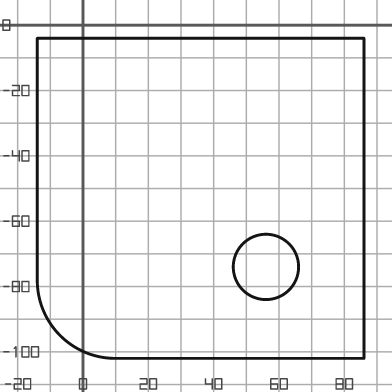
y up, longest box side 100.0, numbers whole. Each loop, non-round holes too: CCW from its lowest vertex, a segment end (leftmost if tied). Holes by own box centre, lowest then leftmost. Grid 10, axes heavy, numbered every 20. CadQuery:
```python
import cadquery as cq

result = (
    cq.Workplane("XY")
    .moveTo(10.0, -102.0)
    .lineTo(86.0, -102.0)
    .lineTo(86.0, -4.0)
    .lineTo(-14.0, -4.0)
    .lineTo(-14.0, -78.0)
    .threePointArc((-7.0, -95.0), (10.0, -102.0))
    .close()
    .moveTo(56.0, -74.0)
    .circle(10.0)
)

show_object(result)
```